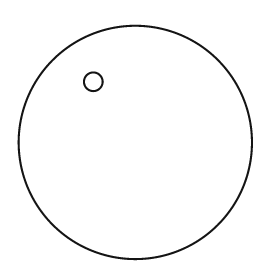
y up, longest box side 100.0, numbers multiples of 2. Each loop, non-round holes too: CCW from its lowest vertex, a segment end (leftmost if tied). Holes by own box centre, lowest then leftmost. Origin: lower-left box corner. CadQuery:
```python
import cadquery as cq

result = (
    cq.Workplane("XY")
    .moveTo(50.0, 50.0)
    .circle(50.0)
    .moveTo(32.0, 76.0)
    .circle(4.0)
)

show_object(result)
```